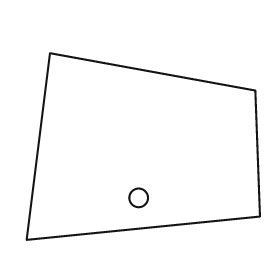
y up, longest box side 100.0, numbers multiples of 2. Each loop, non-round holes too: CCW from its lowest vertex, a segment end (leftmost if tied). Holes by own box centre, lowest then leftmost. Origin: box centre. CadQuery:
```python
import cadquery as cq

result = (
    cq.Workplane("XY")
    .moveTo(-50.0, -40.0)
    .lineTo(50.0, -30.0)
    .lineTo(48.0, 24.0)
    .lineTo(-40.0, 40.0)
    .close()
    .moveTo(-2.0, -22.0)
    .circle(4.0)
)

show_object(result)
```